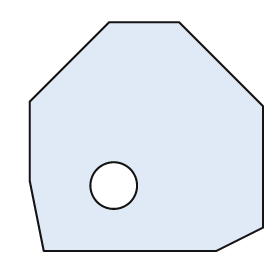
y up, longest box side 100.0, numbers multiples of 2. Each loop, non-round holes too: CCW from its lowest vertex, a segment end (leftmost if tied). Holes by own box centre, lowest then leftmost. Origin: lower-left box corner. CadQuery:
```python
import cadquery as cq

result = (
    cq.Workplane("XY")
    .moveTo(6.0, 0.0)
    .lineTo(80.0, 0.0)
    .lineTo(100.0, 10.0)
    .lineTo(100.0, 62.0)
    .lineTo(64.0, 98.0)
    .lineTo(34.0, 98.0)
    .lineTo(0.0, 64.0)
    .lineTo(0.0, 30.0)
    .close()
    .moveTo(36.0, 28.0)
    .circle(10.0)
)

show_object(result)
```